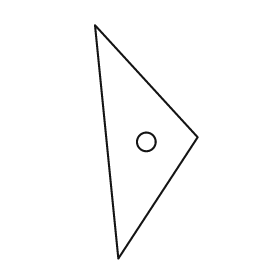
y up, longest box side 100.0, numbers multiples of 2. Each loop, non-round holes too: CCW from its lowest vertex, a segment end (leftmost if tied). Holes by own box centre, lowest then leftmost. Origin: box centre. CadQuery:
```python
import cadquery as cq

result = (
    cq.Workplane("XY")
    .moveTo(-12.0, -50.0)
    .lineTo(22.0, 2.0)
    .lineTo(-22.0, 50.0)
    .close()
    .moveTo(0.0, 0.0)
    .circle(4.0)
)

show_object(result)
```